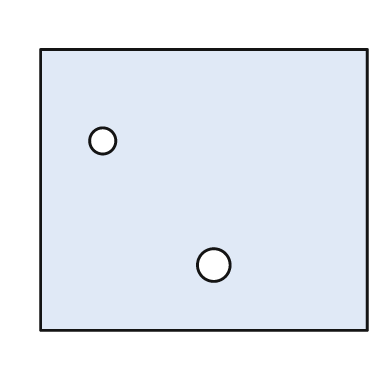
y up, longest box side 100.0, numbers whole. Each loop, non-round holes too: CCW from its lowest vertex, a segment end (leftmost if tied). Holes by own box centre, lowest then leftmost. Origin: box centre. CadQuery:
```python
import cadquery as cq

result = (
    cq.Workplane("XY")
    .moveTo(-50.0, -43.0)
    .lineTo(50.0, -43.0)
    .lineTo(50.0, 43.0)
    .lineTo(-50.0, 43.0)
    .close()
    .moveTo(3.0, -23.0)
    .circle(5.0)
    .moveTo(-31.0, 15.0)
    .circle(4.0)
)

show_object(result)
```